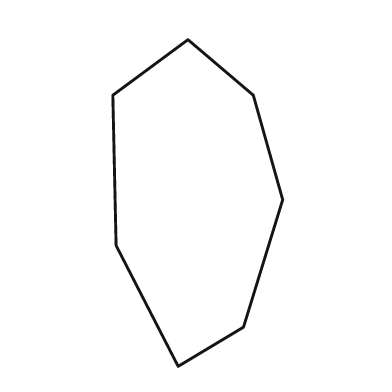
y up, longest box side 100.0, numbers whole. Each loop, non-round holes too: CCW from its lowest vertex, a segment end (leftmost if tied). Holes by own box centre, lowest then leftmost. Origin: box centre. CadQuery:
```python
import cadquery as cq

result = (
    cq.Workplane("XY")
    .moveTo(-6.0, -50.0)
    .lineTo(14.0, -38.0)
    .lineTo(26.0, 1.0)
    .lineTo(17.0, 33.0)
    .lineTo(-3.0, 50.0)
    .lineTo(-26.0, 33.0)
    .lineTo(-25.0, -13.0)
    .close()
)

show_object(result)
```